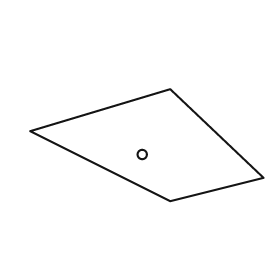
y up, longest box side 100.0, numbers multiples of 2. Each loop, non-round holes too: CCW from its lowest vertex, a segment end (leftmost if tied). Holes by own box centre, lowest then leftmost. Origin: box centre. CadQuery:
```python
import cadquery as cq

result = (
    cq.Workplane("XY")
    .moveTo(10.0, -24.0)
    .lineTo(50.0, -14.0)
    .lineTo(10.0, 24.0)
    .lineTo(-50.0, 6.0)
    .close()
    .moveTo(-2.0, -4.0)
    .circle(2.0)
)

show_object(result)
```